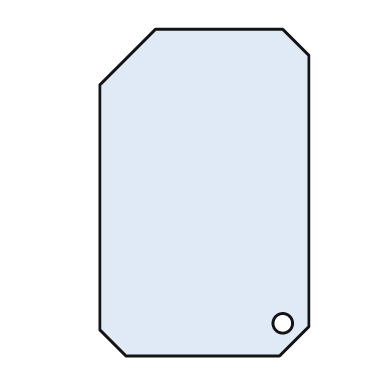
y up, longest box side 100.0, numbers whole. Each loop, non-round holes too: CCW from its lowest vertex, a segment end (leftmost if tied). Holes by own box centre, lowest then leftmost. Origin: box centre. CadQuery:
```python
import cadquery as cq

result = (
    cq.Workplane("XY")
    .moveTo(-24.0, -50.0)
    .lineTo(23.0, -50.0)
    .lineTo(32.0, -41.0)
    .lineTo(32.0, 42.0)
    .lineTo(24.0, 50.0)
    .lineTo(-15.0, 50.0)
    .lineTo(-32.0, 33.0)
    .lineTo(-32.0, -42.0)
    .close()
    .moveTo(24.0, -40.0)
    .circle(3.0)
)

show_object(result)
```